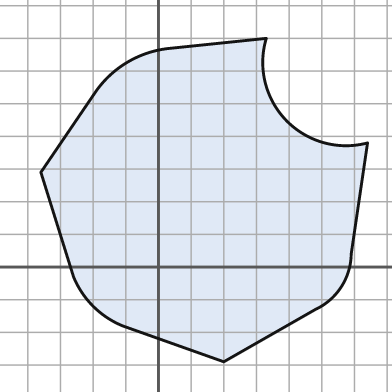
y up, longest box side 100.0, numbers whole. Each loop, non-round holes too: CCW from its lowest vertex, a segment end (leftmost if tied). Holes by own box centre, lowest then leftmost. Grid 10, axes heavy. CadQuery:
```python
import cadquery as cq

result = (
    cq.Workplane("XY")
    .moveTo(20.0, -29.0)
    .lineTo(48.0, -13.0)
    .threePointArc((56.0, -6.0), (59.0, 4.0))
    .lineTo(64.0, 38.0)
    .threePointArc((39.0, 45.0), (33.0, 70.0))
    .lineTo(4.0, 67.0)
    .threePointArc((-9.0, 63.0), (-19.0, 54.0))
    .lineTo(-36.0, 29.0)
    .lineTo(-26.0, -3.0)
    .threePointArc((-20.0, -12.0), (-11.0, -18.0))
    .close()
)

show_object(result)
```